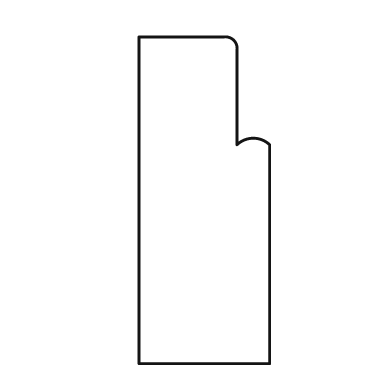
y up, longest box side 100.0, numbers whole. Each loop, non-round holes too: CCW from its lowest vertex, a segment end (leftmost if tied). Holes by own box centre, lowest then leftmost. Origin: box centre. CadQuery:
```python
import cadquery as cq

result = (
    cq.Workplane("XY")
    .moveTo(-20.0, -50.0)
    .lineTo(20.0, -50.0)
    .lineTo(20.0, 17.0)
    .threePointArc((15.0, 19.0), (10.0, 17.0))
    .lineTo(10.0, 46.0)
    .threePointArc((9.0, 49.0), (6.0, 50.0))
    .lineTo(-20.0, 50.0)
    .close()
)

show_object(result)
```